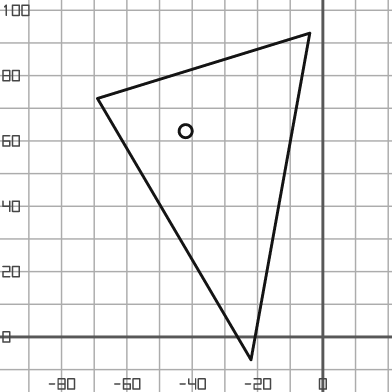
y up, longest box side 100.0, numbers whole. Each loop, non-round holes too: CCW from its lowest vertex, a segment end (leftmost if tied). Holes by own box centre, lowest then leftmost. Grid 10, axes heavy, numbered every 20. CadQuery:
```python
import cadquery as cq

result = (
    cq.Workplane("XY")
    .moveTo(-22.0, -7.0)
    .lineTo(-4.0, 93.0)
    .lineTo(-69.0, 73.0)
    .close()
    .moveTo(-42.0, 63.0)
    .circle(2.0)
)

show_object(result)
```